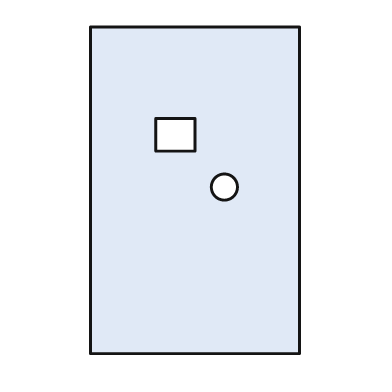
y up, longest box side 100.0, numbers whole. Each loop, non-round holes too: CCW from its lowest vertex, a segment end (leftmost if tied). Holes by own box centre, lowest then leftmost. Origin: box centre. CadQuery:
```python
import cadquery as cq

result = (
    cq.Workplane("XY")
    .moveTo(-32.0, -50.0)
    .lineTo(32.0, -50.0)
    .lineTo(32.0, 50.0)
    .lineTo(-32.0, 50.0)
    .close()
    .moveTo(9.0, 1.0)
    .circle(4.0)
    .moveTo(-12.0, 12.0)
    .lineTo(0.0, 12.0)
    .lineTo(0.0, 22.0)
    .lineTo(-12.0, 22.0)
    .close()
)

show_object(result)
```